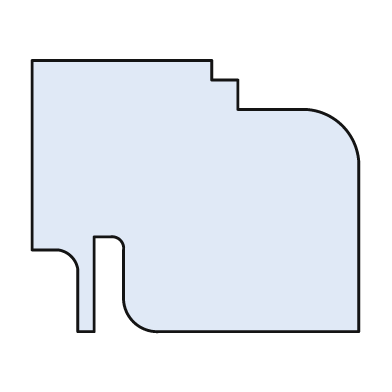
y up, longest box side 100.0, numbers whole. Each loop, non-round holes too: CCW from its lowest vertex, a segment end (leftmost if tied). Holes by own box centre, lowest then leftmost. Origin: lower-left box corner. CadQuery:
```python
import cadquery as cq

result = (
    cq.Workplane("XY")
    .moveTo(14.0, 0.0)
    .lineTo(19.0, 0.0)
    .lineTo(19.0, 29.0)
    .lineTo(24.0, 29.0)
    .threePointArc((27.0, 28.0), (28.0, 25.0))
    .lineTo(28.0, 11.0)
    .threePointArc((31.0, 3.0), (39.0, 0.0))
    .lineTo(100.0, 0.0)
    .lineTo(100.0, 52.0)
    .threePointArc((95.0, 63.0), (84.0, 68.0))
    .lineTo(63.0, 68.0)
    .lineTo(63.0, 77.0)
    .lineTo(55.0, 77.0)
    .lineTo(55.0, 83.0)
    .lineTo(0.0, 83.0)
    .lineTo(0.0, 25.0)
    .lineTo(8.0, 25.0)
    .threePointArc((12.0, 23.0), (14.0, 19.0))
    .close()
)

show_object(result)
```